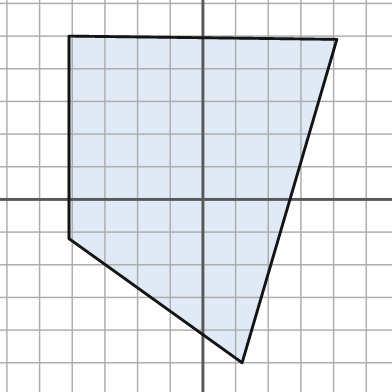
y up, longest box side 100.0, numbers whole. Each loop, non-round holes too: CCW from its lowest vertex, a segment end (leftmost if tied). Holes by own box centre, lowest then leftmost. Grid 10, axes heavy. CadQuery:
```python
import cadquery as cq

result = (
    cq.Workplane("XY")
    .moveTo(12.0, -50.0)
    .lineTo(41.0, 49.0)
    .lineTo(-41.0, 50.0)
    .lineTo(-41.0, -12.0)
    .close()
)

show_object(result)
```